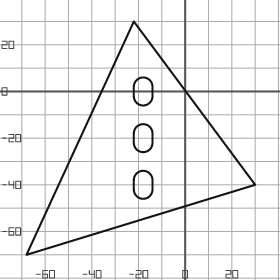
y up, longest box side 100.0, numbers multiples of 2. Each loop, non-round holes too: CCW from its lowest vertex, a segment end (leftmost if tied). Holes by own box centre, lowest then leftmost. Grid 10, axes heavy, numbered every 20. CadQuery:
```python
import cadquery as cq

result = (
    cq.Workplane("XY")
    .moveTo(-68.0, -70.0)
    .lineTo(30.0, -40.0)
    .lineTo(-22.0, 30.0)
    .close()
    .moveTo(-22.0, -42.0)
    .threePointArc((-18.0, -46.0), (-14.0, -42.0))
    .lineTo(-14.0, -38.0)
    .threePointArc((-18.0, -34.0), (-22.0, -38.0))
    .close()
    .moveTo(-22.0, -22.0)
    .threePointArc((-18.0, -26.0), (-14.0, -22.0))
    .lineTo(-14.0, -18.0)
    .threePointArc((-18.0, -14.0), (-22.0, -18.0))
    .close()
    .moveTo(-22.0, -2.0)
    .threePointArc((-18.0, -6.0), (-14.0, -2.0))
    .lineTo(-14.0, 2.0)
    .threePointArc((-18.0, 6.0), (-22.0, 2.0))
    .close()
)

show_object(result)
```